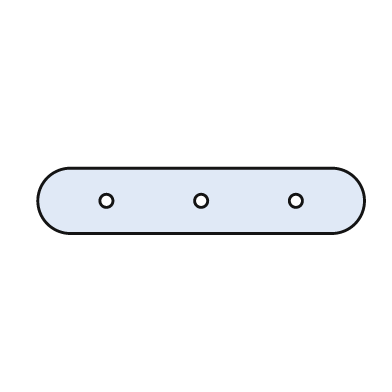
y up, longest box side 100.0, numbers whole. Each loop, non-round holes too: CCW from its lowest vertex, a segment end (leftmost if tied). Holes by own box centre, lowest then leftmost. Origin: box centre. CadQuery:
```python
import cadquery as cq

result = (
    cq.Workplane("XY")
    .moveTo(-40.0, -10.0)
    .lineTo(40.0, -10.0)
    .threePointArc((50.0, 0.0), (40.0, 10.0))
    .lineTo(-40.0, 10.0)
    .threePointArc((-50.0, 0.0), (-40.0, -10.0))
    .close()
    .moveTo(-29.0, 0.0)
    .circle(2.0)
    .moveTo(0.0, 0.0)
    .circle(2.0)
    .moveTo(29.0, 0.0)
    .circle(2.0)
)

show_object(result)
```